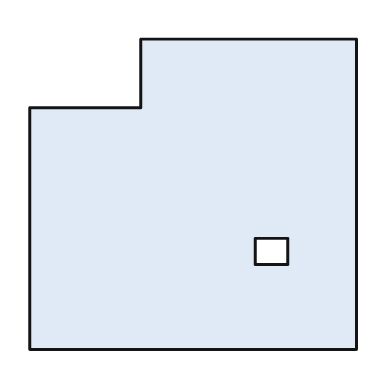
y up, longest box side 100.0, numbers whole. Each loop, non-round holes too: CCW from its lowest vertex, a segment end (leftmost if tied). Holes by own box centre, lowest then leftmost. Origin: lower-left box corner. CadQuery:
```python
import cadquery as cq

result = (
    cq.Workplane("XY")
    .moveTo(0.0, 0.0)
    .lineTo(100.0, 0.0)
    .lineTo(100.0, 95.0)
    .lineTo(34.0, 95.0)
    .lineTo(34.0, 74.0)
    .lineTo(0.0, 74.0)
    .close()
    .moveTo(69.0, 26.0)
    .lineTo(79.0, 26.0)
    .lineTo(79.0, 34.0)
    .lineTo(69.0, 34.0)
    .close()
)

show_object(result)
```